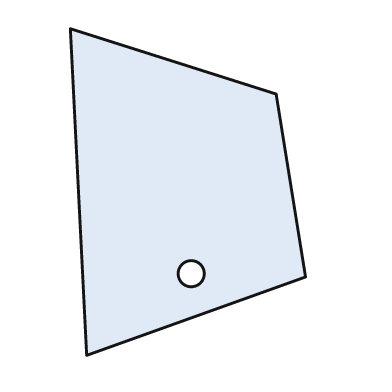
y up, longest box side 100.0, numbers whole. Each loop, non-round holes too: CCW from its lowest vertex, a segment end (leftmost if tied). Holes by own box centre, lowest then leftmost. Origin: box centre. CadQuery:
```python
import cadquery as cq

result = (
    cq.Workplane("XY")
    .moveTo(-31.0, -50.0)
    .lineTo(36.0, -26.0)
    .lineTo(27.0, 30.0)
    .lineTo(-36.0, 50.0)
    .close()
    .moveTo(1.0, -25.0)
    .circle(4.0)
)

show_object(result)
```